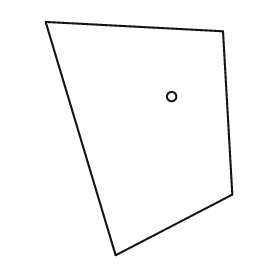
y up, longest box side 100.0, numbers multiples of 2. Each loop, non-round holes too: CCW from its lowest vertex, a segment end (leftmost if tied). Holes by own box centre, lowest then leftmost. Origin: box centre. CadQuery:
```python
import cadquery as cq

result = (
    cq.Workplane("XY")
    .moveTo(-10.0, -50.0)
    .lineTo(40.0, -24.0)
    .lineTo(36.0, 46.0)
    .lineTo(-40.0, 50.0)
    .close()
    .moveTo(14.0, 18.0)
    .circle(2.0)
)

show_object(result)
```